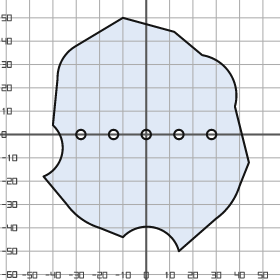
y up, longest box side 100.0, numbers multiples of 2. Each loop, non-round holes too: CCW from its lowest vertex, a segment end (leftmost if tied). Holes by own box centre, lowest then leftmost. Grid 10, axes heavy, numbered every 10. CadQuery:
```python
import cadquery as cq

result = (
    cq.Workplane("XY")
    .moveTo(14.0, -50.0)
    .lineTo(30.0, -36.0)
    .threePointArc((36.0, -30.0), (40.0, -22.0))
    .lineTo(44.0, -12.0)
    .lineTo(38.0, 12.0)
    .threePointArc((36.0, 26.0), (24.0, 34.0))
    .lineTo(12.0, 44.0)
    .lineTo(-10.0, 50.0)
    .lineTo(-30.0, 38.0)
    .threePointArc((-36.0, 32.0), (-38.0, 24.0))
    .lineTo(-40.0, 4.0)
    .threePointArc((-36.0, -8.0), (-44.0, -18.0))
    .lineTo(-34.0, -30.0)
    .threePointArc((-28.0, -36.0), (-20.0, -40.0))
    .lineTo(-10.0, -44.0)
    .threePointArc((4.0, -40.0), (14.0, -50.0))
    .close()
    .moveTo(-28.0, 0.0)
    .circle(2.0)
    .moveTo(-14.0, 0.0)
    .circle(2.0)
    .moveTo(0.0, 0.0)
    .circle(2.0)
    .moveTo(14.0, 0.0)
    .circle(2.0)
    .moveTo(28.0, 0.0)
    .circle(2.0)
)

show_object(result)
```